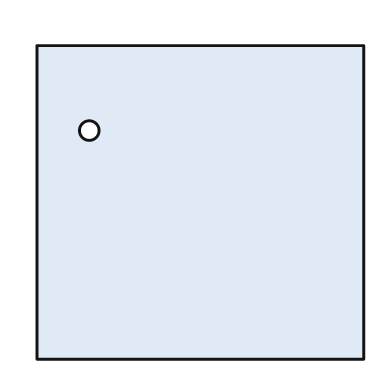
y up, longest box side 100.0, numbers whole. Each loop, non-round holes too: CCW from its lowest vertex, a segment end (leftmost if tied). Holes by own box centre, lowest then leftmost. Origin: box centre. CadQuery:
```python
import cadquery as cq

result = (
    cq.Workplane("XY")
    .moveTo(-50.0, -48.0)
    .lineTo(50.0, -48.0)
    .lineTo(50.0, 48.0)
    .lineTo(-50.0, 48.0)
    .close()
    .moveTo(-34.0, 22.0)
    .circle(3.0)
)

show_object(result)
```